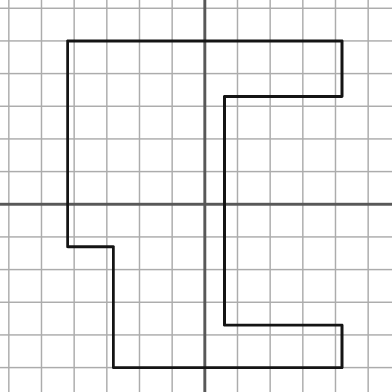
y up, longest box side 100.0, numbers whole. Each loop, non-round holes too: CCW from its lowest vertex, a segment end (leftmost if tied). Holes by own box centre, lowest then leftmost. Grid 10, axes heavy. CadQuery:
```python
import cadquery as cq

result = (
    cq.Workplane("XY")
    .moveTo(-28.0, -50.0)
    .lineTo(42.0, -50.0)
    .lineTo(42.0, -37.0)
    .lineTo(6.0, -37.0)
    .lineTo(6.0, 33.0)
    .lineTo(42.0, 33.0)
    .lineTo(42.0, 50.0)
    .lineTo(-42.0, 50.0)
    .lineTo(-42.0, -13.0)
    .lineTo(-28.0, -13.0)
    .close()
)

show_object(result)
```